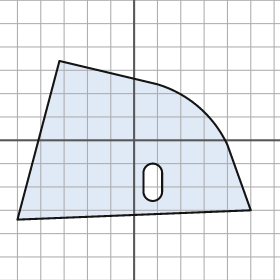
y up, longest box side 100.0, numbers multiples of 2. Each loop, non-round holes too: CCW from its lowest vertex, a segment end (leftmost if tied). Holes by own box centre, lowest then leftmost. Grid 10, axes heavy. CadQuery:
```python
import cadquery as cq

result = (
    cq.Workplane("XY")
    .moveTo(-50.0, -34.0)
    .lineTo(50.0, -30.0)
    .lineTo(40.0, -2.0)
    .threePointArc((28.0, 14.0), (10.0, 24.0))
    .lineTo(-32.0, 34.0)
    .close()
    .moveTo(4.0, -22.0)
    .threePointArc((8.0, -26.0), (12.0, -22.0))
    .lineTo(12.0, -14.0)
    .threePointArc((8.0, -10.0), (4.0, -14.0))
    .close()
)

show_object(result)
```